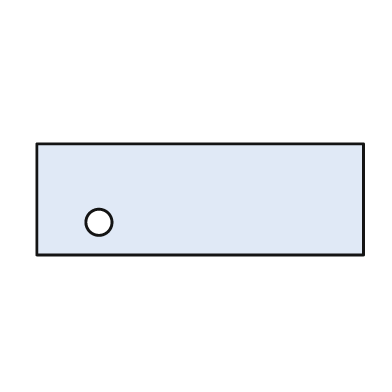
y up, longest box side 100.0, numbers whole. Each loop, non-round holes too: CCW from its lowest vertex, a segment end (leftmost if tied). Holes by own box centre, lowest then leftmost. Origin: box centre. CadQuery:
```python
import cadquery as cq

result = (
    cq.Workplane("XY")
    .moveTo(-50.0, -17.0)
    .lineTo(50.0, -17.0)
    .lineTo(50.0, 17.0)
    .lineTo(-50.0, 17.0)
    .close()
    .moveTo(-31.0, -7.0)
    .circle(4.0)
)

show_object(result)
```